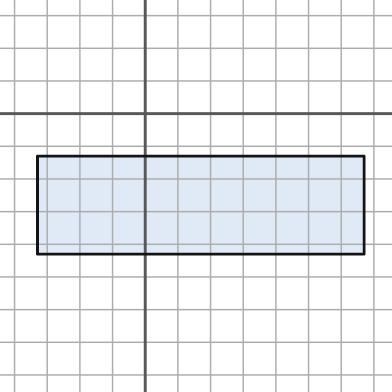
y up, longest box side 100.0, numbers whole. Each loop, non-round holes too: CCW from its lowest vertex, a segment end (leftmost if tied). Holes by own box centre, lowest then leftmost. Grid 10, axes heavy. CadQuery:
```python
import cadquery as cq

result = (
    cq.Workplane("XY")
    .moveTo(-33.0, -43.0)
    .lineTo(67.0, -43.0)
    .lineTo(67.0, -13.0)
    .lineTo(-33.0, -13.0)
    .close()
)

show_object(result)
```